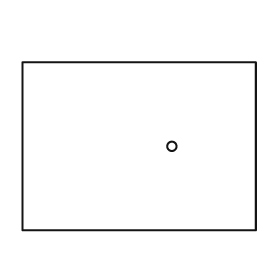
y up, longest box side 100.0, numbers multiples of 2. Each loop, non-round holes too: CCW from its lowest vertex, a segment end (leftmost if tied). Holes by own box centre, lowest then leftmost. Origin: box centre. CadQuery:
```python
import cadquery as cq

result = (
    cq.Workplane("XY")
    .moveTo(-50.0, -36.0)
    .lineTo(50.0, -36.0)
    .lineTo(50.0, 36.0)
    .lineTo(-50.0, 36.0)
    .close()
    .moveTo(14.0, 0.0)
    .circle(2.0)
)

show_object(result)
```